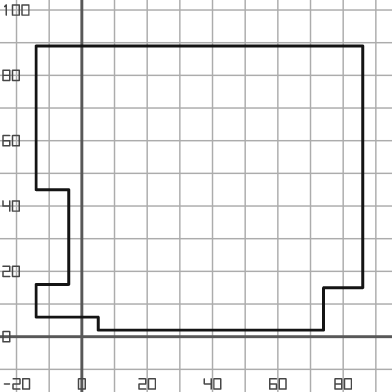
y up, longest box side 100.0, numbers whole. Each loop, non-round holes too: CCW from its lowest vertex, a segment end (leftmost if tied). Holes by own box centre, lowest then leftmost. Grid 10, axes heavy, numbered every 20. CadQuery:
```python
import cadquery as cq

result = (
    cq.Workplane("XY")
    .moveTo(5.0, 2.0)
    .lineTo(74.0, 2.0)
    .lineTo(74.0, 15.0)
    .lineTo(86.0, 15.0)
    .lineTo(86.0, 89.0)
    .lineTo(-14.0, 89.0)
    .lineTo(-14.0, 45.0)
    .lineTo(-4.0, 45.0)
    .lineTo(-4.0, 16.0)
    .lineTo(-14.0, 16.0)
    .lineTo(-14.0, 6.0)
    .lineTo(5.0, 6.0)
    .close()
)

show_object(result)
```